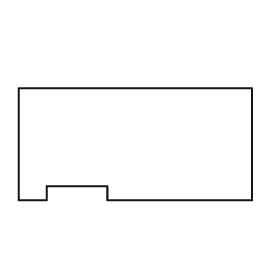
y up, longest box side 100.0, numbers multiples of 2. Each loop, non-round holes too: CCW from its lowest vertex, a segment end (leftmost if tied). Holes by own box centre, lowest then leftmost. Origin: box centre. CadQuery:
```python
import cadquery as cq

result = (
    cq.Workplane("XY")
    .moveTo(-50.0, -24.0)
    .lineTo(-38.0, -24.0)
    .lineTo(-38.0, -18.0)
    .lineTo(-12.0, -18.0)
    .lineTo(-12.0, -24.0)
    .lineTo(50.0, -24.0)
    .lineTo(50.0, 24.0)
    .lineTo(-50.0, 24.0)
    .close()
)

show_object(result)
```